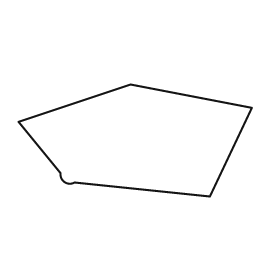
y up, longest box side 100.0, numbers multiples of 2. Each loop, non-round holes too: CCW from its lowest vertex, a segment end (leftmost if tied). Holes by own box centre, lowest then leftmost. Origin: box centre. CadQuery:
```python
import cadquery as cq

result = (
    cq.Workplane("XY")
    .moveTo(32.0, -24.0)
    .lineTo(50.0, 14.0)
    .lineTo(-2.0, 24.0)
    .lineTo(-50.0, 8.0)
    .lineTo(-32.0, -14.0)
    .threePointArc((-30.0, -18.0), (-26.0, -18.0))
    .close()
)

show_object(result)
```